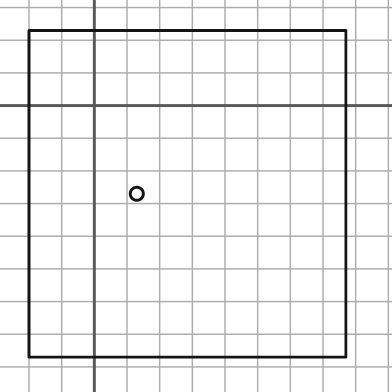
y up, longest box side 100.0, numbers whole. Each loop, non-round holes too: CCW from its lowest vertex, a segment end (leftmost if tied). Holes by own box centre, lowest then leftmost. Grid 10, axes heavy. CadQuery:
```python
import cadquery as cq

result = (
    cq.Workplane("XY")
    .moveTo(-20.0, -77.0)
    .lineTo(77.0, -77.0)
    .lineTo(77.0, 23.0)
    .lineTo(-20.0, 23.0)
    .close()
    .moveTo(13.0, -27.0)
    .circle(2.0)
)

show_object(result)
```